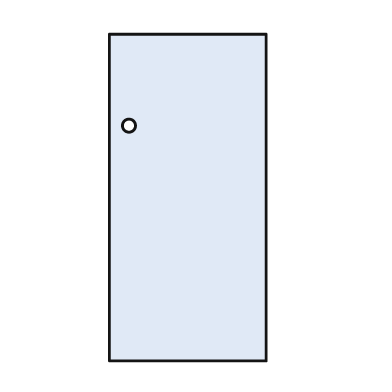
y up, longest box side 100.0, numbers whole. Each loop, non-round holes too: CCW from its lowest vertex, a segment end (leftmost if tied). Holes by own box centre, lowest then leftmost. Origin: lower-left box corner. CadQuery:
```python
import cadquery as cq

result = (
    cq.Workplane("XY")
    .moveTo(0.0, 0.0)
    .lineTo(48.0, 0.0)
    .lineTo(48.0, 100.0)
    .lineTo(0.0, 100.0)
    .close()
    .moveTo(6.0, 72.0)
    .circle(2.0)
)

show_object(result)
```